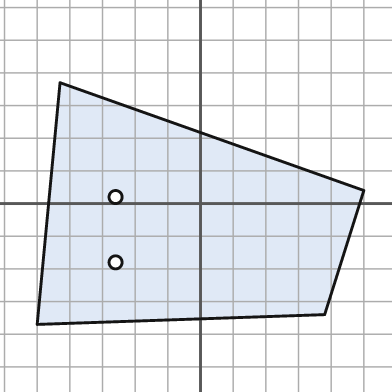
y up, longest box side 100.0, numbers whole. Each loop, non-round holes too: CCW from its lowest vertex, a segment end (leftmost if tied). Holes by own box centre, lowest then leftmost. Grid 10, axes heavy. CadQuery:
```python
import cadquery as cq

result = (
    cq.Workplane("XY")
    .moveTo(-50.0, -37.0)
    .lineTo(38.0, -34.0)
    .lineTo(50.0, 4.0)
    .lineTo(-43.0, 37.0)
    .close()
    .moveTo(-26.0, -18.0)
    .circle(2.0)
    .moveTo(-26.0, 2.0)
    .circle(2.0)
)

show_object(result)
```